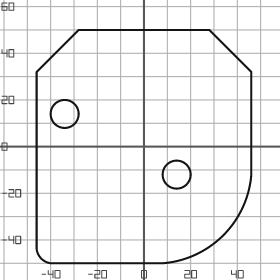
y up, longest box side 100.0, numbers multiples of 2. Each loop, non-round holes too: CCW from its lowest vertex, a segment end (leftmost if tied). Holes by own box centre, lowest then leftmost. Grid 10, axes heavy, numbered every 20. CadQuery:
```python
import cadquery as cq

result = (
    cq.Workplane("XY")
    .moveTo(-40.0, -50.0)
    .lineTo(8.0, -50.0)
    .threePointArc((34.0, -38.0), (46.0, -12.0))
    .lineTo(46.0, 32.0)
    .lineTo(28.0, 50.0)
    .lineTo(-28.0, 50.0)
    .lineTo(-46.0, 32.0)
    .lineTo(-46.0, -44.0)
    .threePointArc((-44.0, -48.0), (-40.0, -50.0))
    .close()
    .moveTo(14.0, -12.0)
    .circle(6.0)
    .moveTo(-34.0, 14.0)
    .circle(6.0)
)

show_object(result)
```